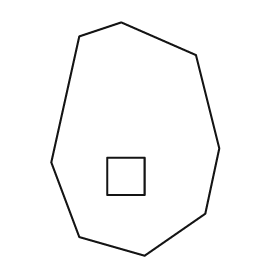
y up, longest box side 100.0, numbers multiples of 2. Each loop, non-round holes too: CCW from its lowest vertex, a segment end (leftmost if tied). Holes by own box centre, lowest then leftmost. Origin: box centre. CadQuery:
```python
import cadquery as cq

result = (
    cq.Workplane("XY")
    .moveTo(4.0, -50.0)
    .lineTo(30.0, -32.0)
    .lineTo(36.0, -4.0)
    .lineTo(26.0, 36.0)
    .lineTo(-6.0, 50.0)
    .lineTo(-24.0, 44.0)
    .lineTo(-36.0, -10.0)
    .lineTo(-24.0, -42.0)
    .close()
    .moveTo(-12.0, -24.0)
    .lineTo(4.0, -24.0)
    .lineTo(4.0, -8.0)
    .lineTo(-12.0, -8.0)
    .close()
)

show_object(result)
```